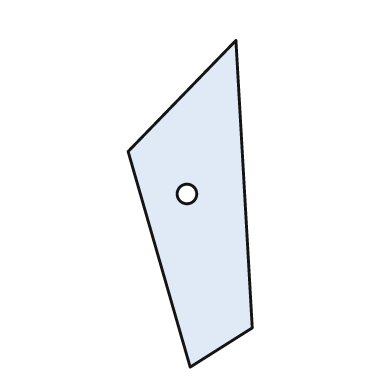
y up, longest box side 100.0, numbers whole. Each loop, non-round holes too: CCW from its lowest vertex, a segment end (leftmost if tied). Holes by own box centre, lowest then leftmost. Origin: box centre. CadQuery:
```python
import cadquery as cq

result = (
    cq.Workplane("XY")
    .moveTo(0.0, -50.0)
    .lineTo(19.0, -38.0)
    .lineTo(14.0, 50.0)
    .lineTo(-19.0, 16.0)
    .close()
    .moveTo(-1.0, 3.0)
    .circle(3.0)
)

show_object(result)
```